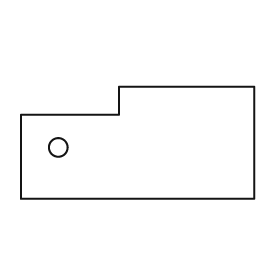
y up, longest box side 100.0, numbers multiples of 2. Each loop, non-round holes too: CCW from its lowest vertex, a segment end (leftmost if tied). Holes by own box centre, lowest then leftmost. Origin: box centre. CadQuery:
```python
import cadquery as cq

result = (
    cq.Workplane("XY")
    .moveTo(-50.0, -24.0)
    .lineTo(50.0, -24.0)
    .lineTo(50.0, 24.0)
    .lineTo(-8.0, 24.0)
    .lineTo(-8.0, 12.0)
    .lineTo(-50.0, 12.0)
    .close()
    .moveTo(-34.0, -2.0)
    .circle(4.0)
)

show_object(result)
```